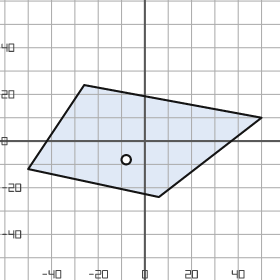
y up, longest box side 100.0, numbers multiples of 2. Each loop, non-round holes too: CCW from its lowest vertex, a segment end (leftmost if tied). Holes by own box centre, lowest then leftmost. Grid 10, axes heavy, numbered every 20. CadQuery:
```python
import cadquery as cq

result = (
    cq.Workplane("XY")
    .moveTo(6.0, -24.0)
    .lineTo(50.0, 10.0)
    .lineTo(-26.0, 24.0)
    .lineTo(-50.0, -12.0)
    .close()
    .moveTo(-8.0, -8.0)
    .circle(2.0)
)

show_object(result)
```